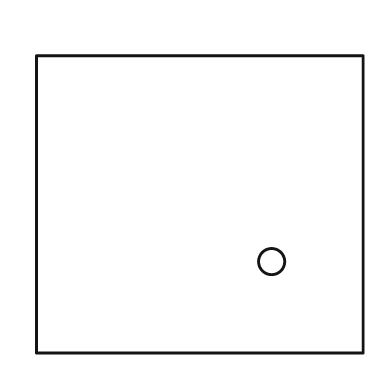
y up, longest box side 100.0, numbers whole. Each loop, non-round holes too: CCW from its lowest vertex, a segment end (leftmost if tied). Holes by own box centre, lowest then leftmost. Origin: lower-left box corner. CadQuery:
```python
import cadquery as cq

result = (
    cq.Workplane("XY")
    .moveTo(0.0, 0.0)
    .lineTo(100.0, 0.0)
    .lineTo(100.0, 91.0)
    .lineTo(0.0, 91.0)
    .close()
    .moveTo(72.0, 28.0)
    .circle(4.0)
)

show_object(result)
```